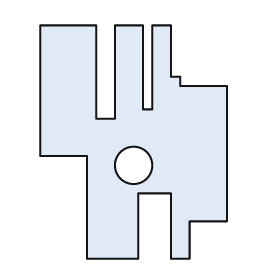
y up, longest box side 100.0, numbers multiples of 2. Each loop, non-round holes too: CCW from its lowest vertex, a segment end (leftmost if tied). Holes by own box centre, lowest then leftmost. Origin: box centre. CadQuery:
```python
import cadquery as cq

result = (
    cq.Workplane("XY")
    .moveTo(-20.0, -50.0)
    .lineTo(2.0, -50.0)
    .lineTo(2.0, -22.0)
    .lineTo(16.0, -22.0)
    .lineTo(16.0, -50.0)
    .lineTo(24.0, -50.0)
    .lineTo(24.0, -34.0)
    .lineTo(40.0, -34.0)
    .lineTo(40.0, 24.0)
    .lineTo(20.0, 24.0)
    .lineTo(20.0, 28.0)
    .lineTo(16.0, 28.0)
    .lineTo(16.0, 50.0)
    .lineTo(8.0, 50.0)
    .lineTo(8.0, 14.0)
    .lineTo(4.0, 14.0)
    .lineTo(4.0, 50.0)
    .lineTo(-8.0, 50.0)
    .lineTo(-8.0, 10.0)
    .lineTo(-16.0, 10.0)
    .lineTo(-16.0, 50.0)
    .lineTo(-40.0, 50.0)
    .lineTo(-40.0, -6.0)
    .lineTo(-20.0, -6.0)
    .close()
    .moveTo(0.0, -10.0)
    .circle(8.0)
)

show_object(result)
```